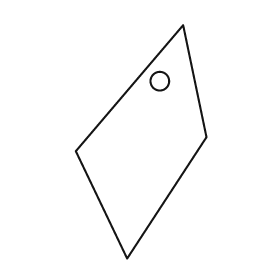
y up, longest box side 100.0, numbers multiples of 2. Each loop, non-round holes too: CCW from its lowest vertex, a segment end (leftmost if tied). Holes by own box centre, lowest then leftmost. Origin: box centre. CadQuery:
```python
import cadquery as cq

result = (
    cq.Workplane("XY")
    .moveTo(-6.0, -50.0)
    .lineTo(28.0, 2.0)
    .lineTo(18.0, 50.0)
    .lineTo(-28.0, -4.0)
    .close()
    .moveTo(8.0, 26.0)
    .circle(4.0)
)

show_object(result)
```